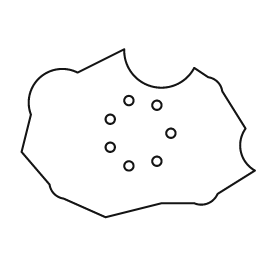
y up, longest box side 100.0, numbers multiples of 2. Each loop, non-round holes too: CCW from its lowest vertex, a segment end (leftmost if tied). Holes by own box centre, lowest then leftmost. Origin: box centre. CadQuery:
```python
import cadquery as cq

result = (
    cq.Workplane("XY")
    .moveTo(-14.0, -36.0)
    .lineTo(10.0, -30.0)
    .lineTo(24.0, -30.0)
    .threePointArc((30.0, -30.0), (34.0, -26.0))
    .lineTo(50.0, -16.0)
    .threePointArc((44.0, -8.0), (46.0, 2.0))
    .lineTo(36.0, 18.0)
    .threePointArc((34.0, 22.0), (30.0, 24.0))
    .lineTo(24.0, 28.0)
    .threePointArc((6.0, 20.0), (-6.0, 36.0))
    .lineTo(-26.0, 26.0)
    .threePointArc((-42.0, 24.0), (-46.0, 8.0))
    .lineTo(-50.0, -8.0)
    .lineTo(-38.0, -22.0)
    .threePointArc((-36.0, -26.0), (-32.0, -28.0))
    .close()
    .moveTo(-4.0, -14.0)
    .circle(2.0)
    .moveTo(8.0, -12.0)
    .circle(2.0)
    .moveTo(-12.0, -6.0)
    .circle(2.0)
    .moveTo(14.0, 0.0)
    .circle(2.0)
    .moveTo(-12.0, 6.0)
    .circle(2.0)
    .moveTo(8.0, 12.0)
    .circle(2.0)
    .moveTo(-4.0, 14.0)
    .circle(2.0)
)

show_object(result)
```